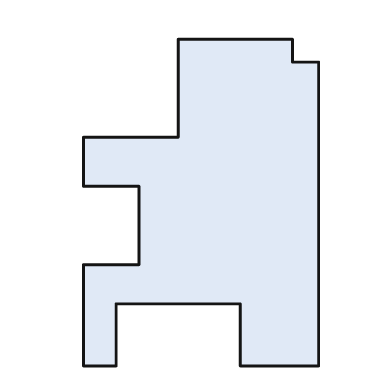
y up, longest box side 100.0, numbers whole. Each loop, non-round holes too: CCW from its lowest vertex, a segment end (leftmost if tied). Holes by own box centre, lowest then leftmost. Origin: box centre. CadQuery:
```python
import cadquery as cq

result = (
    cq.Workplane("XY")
    .moveTo(-36.0, -50.0)
    .lineTo(-26.0, -50.0)
    .lineTo(-26.0, -31.0)
    .lineTo(12.0, -31.0)
    .lineTo(12.0, -50.0)
    .lineTo(36.0, -50.0)
    .lineTo(36.0, 43.0)
    .lineTo(28.0, 43.0)
    .lineTo(28.0, 50.0)
    .lineTo(-7.0, 50.0)
    .lineTo(-7.0, 20.0)
    .lineTo(-36.0, 20.0)
    .lineTo(-36.0, 5.0)
    .lineTo(-19.0, 5.0)
    .lineTo(-19.0, -19.0)
    .lineTo(-36.0, -19.0)
    .close()
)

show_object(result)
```